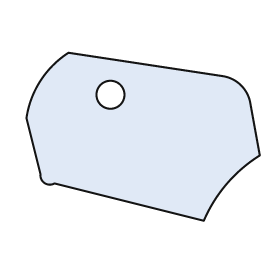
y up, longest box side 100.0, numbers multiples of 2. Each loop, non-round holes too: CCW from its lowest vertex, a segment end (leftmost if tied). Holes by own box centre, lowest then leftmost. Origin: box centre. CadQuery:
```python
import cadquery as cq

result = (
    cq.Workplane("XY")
    .moveTo(26.0, -36.0)
    .threePointArc((36.0, -20.0), (50.0, -8.0))
    .lineTo(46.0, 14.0)
    .threePointArc((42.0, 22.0), (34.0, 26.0))
    .lineTo(-32.0, 36.0)
    .threePointArc((-44.0, 24.0), (-50.0, 8.0))
    .lineTo(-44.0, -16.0)
    .threePointArc((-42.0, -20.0), (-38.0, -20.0))
    .close()
    .moveTo(-14.0, 18.0)
    .circle(6.0)
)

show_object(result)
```